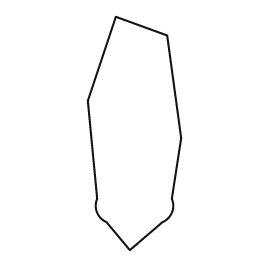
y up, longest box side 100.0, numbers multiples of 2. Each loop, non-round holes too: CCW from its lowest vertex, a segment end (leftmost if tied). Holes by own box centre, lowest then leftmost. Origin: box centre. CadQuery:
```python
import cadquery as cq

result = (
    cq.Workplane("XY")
    .moveTo(-2.0, -50.0)
    .lineTo(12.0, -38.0)
    .threePointArc((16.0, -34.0), (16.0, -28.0))
    .lineTo(20.0, -2.0)
    .lineTo(14.0, 42.0)
    .lineTo(-8.0, 50.0)
    .lineTo(-20.0, 14.0)
    .lineTo(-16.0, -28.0)
    .threePointArc((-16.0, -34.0), (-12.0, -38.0))
    .close()
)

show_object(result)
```